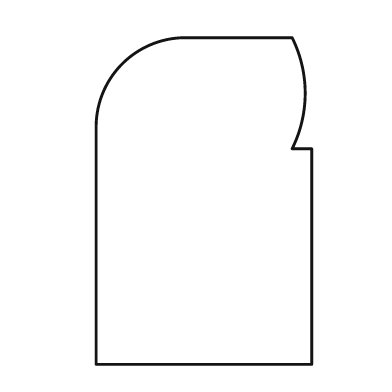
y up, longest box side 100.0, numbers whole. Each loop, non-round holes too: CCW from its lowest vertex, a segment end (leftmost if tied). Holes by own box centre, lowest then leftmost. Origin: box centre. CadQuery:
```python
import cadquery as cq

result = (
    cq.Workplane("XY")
    .moveTo(-33.0, -50.0)
    .lineTo(33.0, -50.0)
    .lineTo(33.0, 16.0)
    .lineTo(27.0, 16.0)
    .threePointArc((31.0, 33.0), (27.0, 50.0))
    .lineTo(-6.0, 50.0)
    .threePointArc((-25.0, 42.0), (-33.0, 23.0))
    .close()
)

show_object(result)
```